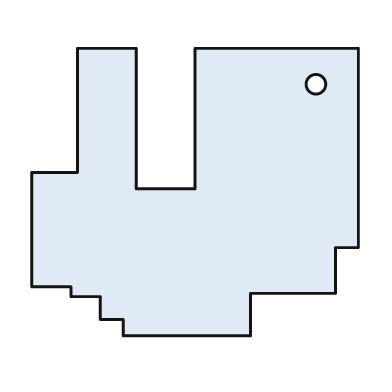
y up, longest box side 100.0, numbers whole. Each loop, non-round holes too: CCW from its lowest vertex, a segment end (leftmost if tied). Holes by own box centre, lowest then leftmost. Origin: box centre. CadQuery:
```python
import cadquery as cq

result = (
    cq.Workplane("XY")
    .moveTo(-22.0, -44.0)
    .lineTo(17.0, -44.0)
    .lineTo(17.0, -31.0)
    .lineTo(43.0, -31.0)
    .lineTo(43.0, -17.0)
    .lineTo(50.0, -17.0)
    .lineTo(50.0, 44.0)
    .lineTo(0.0, 44.0)
    .lineTo(0.0, 1.0)
    .lineTo(-18.0, 1.0)
    .lineTo(-18.0, 44.0)
    .lineTo(-36.0, 44.0)
    .lineTo(-36.0, 6.0)
    .lineTo(-50.0, 6.0)
    .lineTo(-50.0, -29.0)
    .lineTo(-38.0, -29.0)
    .lineTo(-38.0, -32.0)
    .lineTo(-29.0, -32.0)
    .lineTo(-29.0, -39.0)
    .lineTo(-22.0, -39.0)
    .close()
    .moveTo(37.0, 33.0)
    .circle(3.0)
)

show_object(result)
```